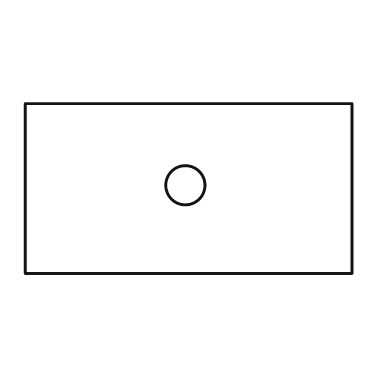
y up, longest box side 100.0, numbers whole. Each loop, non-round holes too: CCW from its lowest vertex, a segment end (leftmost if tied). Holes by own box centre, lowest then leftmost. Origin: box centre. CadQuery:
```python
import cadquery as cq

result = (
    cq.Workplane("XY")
    .moveTo(-50.0, -26.0)
    .lineTo(50.0, -26.0)
    .lineTo(50.0, 26.0)
    .lineTo(-50.0, 26.0)
    .close()
    .moveTo(-1.0, 1.0)
    .circle(6.0)
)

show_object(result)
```